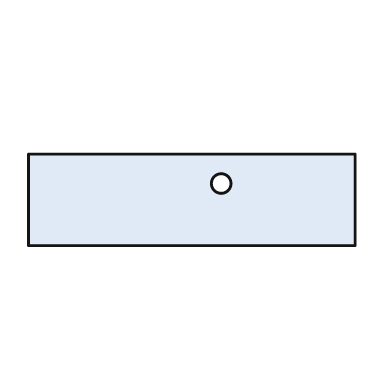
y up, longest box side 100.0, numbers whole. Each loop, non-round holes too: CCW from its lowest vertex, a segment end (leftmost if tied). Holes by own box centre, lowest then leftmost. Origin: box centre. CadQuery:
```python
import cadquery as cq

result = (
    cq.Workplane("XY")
    .moveTo(-50.0, -14.0)
    .lineTo(50.0, -14.0)
    .lineTo(50.0, 14.0)
    .lineTo(-50.0, 14.0)
    .close()
    .moveTo(9.0, 5.0)
    .circle(3.0)
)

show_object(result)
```